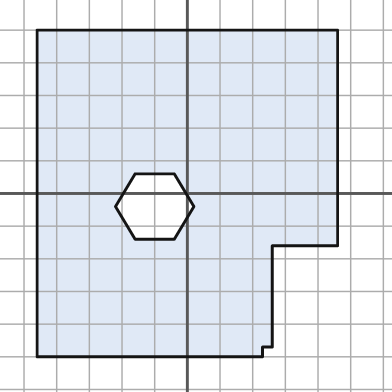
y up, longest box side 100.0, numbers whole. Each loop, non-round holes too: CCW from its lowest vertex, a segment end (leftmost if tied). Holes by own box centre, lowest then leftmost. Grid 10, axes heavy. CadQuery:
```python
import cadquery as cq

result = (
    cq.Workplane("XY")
    .moveTo(-46.0, -50.0)
    .lineTo(23.0, -50.0)
    .lineTo(23.0, -47.0)
    .lineTo(26.0, -47.0)
    .lineTo(26.0, -16.0)
    .lineTo(46.0, -16.0)
    .lineTo(46.0, 50.0)
    .lineTo(-46.0, 50.0)
    .close()
    .moveTo(-16.0, -14.0)
    .lineTo(-4.0, -14.0)
    .lineTo(2.0, -4.0)
    .lineTo(-4.0, 6.0)
    .lineTo(-16.0, 6.0)
    .lineTo(-22.0, -4.0)
    .close()
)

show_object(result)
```